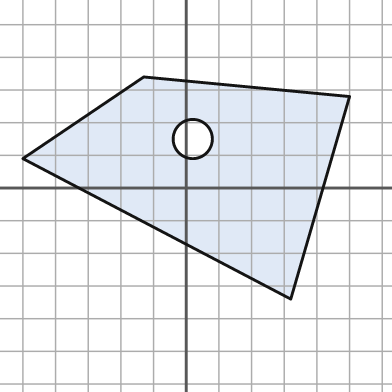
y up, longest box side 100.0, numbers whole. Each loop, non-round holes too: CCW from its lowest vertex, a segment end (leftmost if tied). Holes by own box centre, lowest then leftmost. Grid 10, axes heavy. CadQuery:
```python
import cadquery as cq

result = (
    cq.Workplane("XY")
    .moveTo(32.0, -34.0)
    .lineTo(50.0, 28.0)
    .lineTo(-13.0, 34.0)
    .lineTo(-50.0, 9.0)
    .close()
    .moveTo(2.0, 15.0)
    .circle(6.0)
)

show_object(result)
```